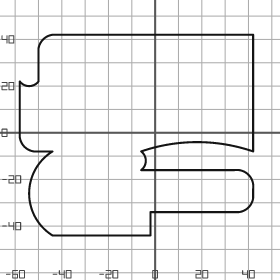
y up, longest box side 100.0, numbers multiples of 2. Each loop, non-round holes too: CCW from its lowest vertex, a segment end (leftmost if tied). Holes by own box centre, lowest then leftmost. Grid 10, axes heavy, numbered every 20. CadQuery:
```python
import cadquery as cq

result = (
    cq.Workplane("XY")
    .moveTo(-44.0, -44.0)
    .lineTo(-2.0, -44.0)
    .lineTo(-2.0, -34.0)
    .lineTo(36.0, -34.0)
    .threePointArc((40.0, -32.0), (42.0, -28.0))
    .lineTo(42.0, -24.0)
    .threePointArc((40.0, -18.0), (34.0, -16.0))
    .lineTo(-6.0, -16.0)
    .threePointArc((-4.0, -12.0), (-6.0, -8.0))
    .threePointArc((18.0, -4.0), (42.0, -8.0))
    .lineTo(42.0, 42.0)
    .lineTo(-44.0, 42.0)
    .threePointArc((-48.0, 40.0), (-50.0, 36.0))
    .lineTo(-50.0, 22.0)
    .threePointArc((-54.0, 20.0), (-58.0, 22.0))
    .lineTo(-58.0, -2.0)
    .threePointArc((-56.0, -6.0), (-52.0, -8.0))
    .lineTo(-44.0, -8.0)
    .threePointArc((-54.0, -26.0), (-44.0, -44.0))
    .close()
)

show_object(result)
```